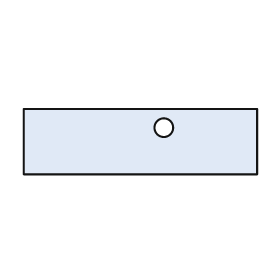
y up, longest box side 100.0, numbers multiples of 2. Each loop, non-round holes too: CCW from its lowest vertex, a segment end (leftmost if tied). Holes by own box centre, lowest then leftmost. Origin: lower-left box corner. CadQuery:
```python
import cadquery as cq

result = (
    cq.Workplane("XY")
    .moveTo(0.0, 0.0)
    .lineTo(100.0, 0.0)
    .lineTo(100.0, 28.0)
    .lineTo(0.0, 28.0)
    .close()
    .moveTo(60.0, 20.0)
    .circle(4.0)
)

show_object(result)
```